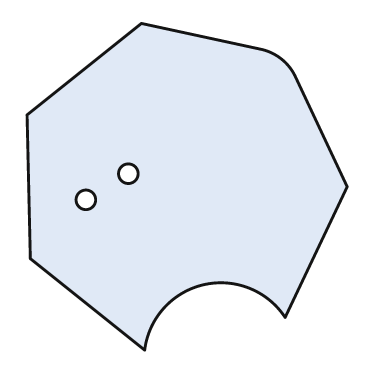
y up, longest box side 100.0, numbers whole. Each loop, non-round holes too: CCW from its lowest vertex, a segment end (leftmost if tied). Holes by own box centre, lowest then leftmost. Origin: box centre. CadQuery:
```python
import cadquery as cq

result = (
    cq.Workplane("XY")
    .moveTo(-13.0, -50.0)
    .threePointArc((5.0, -30.0), (30.0, -40.0))
    .lineTo(49.0, 0.0)
    .lineTo(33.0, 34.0)
    .threePointArc((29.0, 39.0), (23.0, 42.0))
    .lineTo(-14.0, 50.0)
    .lineTo(-49.0, 22.0)
    .lineTo(-48.0, -22.0)
    .close()
    .moveTo(-31.0, -4.0)
    .circle(3.0)
    .moveTo(-18.0, 4.0)
    .circle(3.0)
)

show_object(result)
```